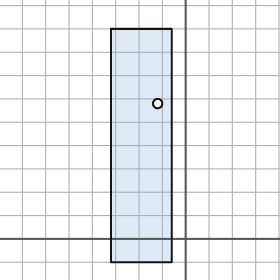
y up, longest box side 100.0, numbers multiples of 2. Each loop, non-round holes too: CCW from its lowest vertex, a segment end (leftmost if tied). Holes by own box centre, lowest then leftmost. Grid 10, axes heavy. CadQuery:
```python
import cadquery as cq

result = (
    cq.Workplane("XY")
    .moveTo(-32.0, -10.0)
    .lineTo(-6.0, -10.0)
    .lineTo(-6.0, 90.0)
    .lineTo(-32.0, 90.0)
    .close()
    .moveTo(-12.0, 58.0)
    .circle(2.0)
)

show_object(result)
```